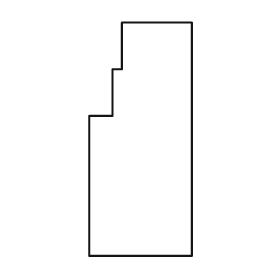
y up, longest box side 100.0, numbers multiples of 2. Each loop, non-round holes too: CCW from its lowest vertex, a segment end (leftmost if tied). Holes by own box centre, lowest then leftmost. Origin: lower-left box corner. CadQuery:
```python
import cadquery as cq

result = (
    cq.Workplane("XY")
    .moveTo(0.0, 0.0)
    .lineTo(44.0, 0.0)
    .lineTo(44.0, 100.0)
    .lineTo(14.0, 100.0)
    .lineTo(14.0, 80.0)
    .lineTo(10.0, 80.0)
    .lineTo(10.0, 60.0)
    .lineTo(0.0, 60.0)
    .close()
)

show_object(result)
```